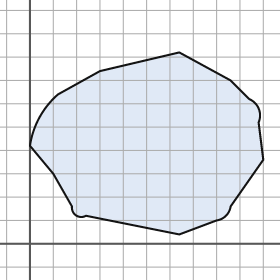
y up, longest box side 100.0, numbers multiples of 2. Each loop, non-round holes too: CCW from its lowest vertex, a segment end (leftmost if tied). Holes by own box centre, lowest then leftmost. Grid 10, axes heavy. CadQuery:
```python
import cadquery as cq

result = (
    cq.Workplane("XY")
    .moveTo(64.0, 4.0)
    .lineTo(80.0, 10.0)
    .threePointArc((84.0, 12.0), (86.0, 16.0))
    .lineTo(100.0, 36.0)
    .lineTo(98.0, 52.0)
    .threePointArc((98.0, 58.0), (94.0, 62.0))
    .lineTo(86.0, 70.0)
    .lineTo(64.0, 82.0)
    .lineTo(30.0, 74.0)
    .lineTo(12.0, 64.0)
    .threePointArc((4.0, 54.0), (0.0, 42.0))
    .lineTo(10.0, 30.0)
    .lineTo(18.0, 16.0)
    .threePointArc((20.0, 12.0), (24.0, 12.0))
    .close()
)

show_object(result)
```